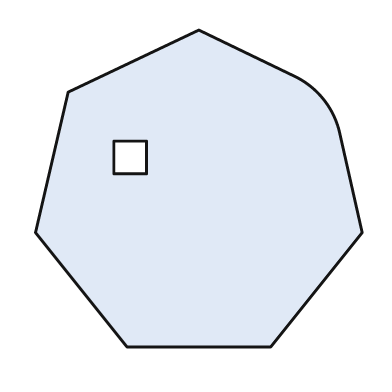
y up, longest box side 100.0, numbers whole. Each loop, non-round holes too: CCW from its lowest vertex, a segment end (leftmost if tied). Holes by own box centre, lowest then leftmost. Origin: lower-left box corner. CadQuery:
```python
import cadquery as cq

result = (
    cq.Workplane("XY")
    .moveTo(28.0, 0.0)
    .lineTo(72.0, 0.0)
    .lineTo(100.0, 35.0)
    .lineTo(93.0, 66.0)
    .threePointArc((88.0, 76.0), (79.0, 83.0))
    .lineTo(50.0, 97.0)
    .lineTo(10.0, 78.0)
    .lineTo(0.0, 35.0)
    .close()
    .moveTo(24.0, 53.0)
    .lineTo(34.0, 53.0)
    .lineTo(34.0, 63.0)
    .lineTo(24.0, 63.0)
    .close()
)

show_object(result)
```